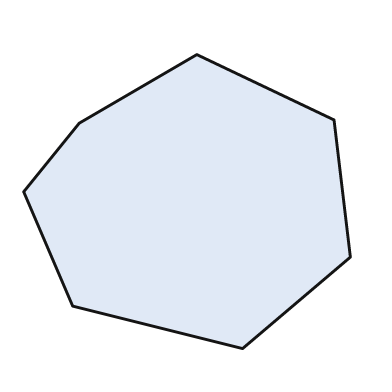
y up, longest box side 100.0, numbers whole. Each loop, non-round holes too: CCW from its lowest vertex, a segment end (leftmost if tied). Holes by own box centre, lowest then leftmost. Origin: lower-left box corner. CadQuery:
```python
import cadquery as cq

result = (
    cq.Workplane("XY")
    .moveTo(67.0, 0.0)
    .lineTo(100.0, 28.0)
    .lineTo(95.0, 70.0)
    .lineTo(53.0, 90.0)
    .lineTo(17.0, 69.0)
    .lineTo(0.0, 48.0)
    .lineTo(15.0, 13.0)
    .close()
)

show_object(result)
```